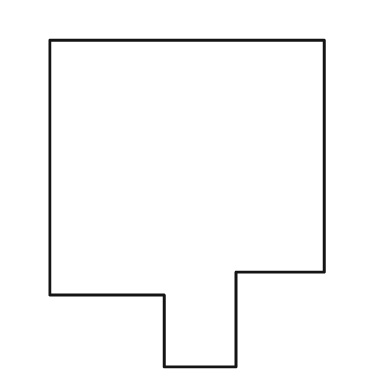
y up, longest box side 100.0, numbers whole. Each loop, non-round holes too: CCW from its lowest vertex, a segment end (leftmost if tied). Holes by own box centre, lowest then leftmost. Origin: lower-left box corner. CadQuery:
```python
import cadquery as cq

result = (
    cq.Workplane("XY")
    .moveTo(35.0, 0.0)
    .lineTo(57.0, 0.0)
    .lineTo(57.0, 29.0)
    .lineTo(84.0, 29.0)
    .lineTo(84.0, 100.0)
    .lineTo(0.0, 100.0)
    .lineTo(0.0, 22.0)
    .lineTo(35.0, 22.0)
    .close()
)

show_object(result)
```